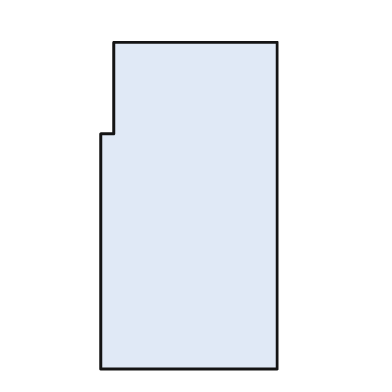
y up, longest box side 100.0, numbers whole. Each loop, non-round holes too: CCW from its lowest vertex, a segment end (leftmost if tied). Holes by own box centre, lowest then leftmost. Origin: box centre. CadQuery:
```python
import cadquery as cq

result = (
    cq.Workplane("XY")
    .moveTo(-27.0, -50.0)
    .lineTo(27.0, -50.0)
    .lineTo(27.0, 50.0)
    .lineTo(-23.0, 50.0)
    .lineTo(-23.0, 22.0)
    .lineTo(-27.0, 22.0)
    .close()
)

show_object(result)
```